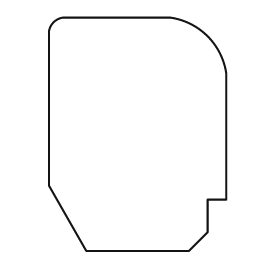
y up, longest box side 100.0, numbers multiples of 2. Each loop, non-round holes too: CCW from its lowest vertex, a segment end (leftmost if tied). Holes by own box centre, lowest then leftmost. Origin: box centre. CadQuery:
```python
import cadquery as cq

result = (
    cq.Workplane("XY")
    .moveTo(-22.0, -50.0)
    .lineTo(22.0, -50.0)
    .lineTo(30.0, -42.0)
    .lineTo(30.0, -28.0)
    .lineTo(38.0, -28.0)
    .lineTo(38.0, 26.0)
    .threePointArc((30.0, 42.0), (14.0, 50.0))
    .lineTo(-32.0, 50.0)
    .threePointArc((-36.0, 48.0), (-38.0, 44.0))
    .lineTo(-38.0, -22.0)
    .close()
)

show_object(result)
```